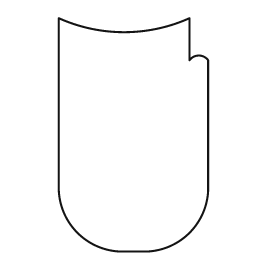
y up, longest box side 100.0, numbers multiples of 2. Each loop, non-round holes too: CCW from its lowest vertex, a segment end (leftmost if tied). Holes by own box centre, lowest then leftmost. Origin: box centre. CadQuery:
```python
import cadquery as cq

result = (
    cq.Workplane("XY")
    .moveTo(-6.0, -50.0)
    .lineTo(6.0, -50.0)
    .threePointArc((24.0, -42.0), (32.0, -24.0))
    .lineTo(32.0, 32.0)
    .threePointArc((28.0, 34.0), (24.0, 32.0))
    .lineTo(24.0, 50.0)
    .threePointArc((-4.0, 44.0), (-32.0, 50.0))
    .lineTo(-32.0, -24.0)
    .threePointArc((-24.0, -42.0), (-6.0, -50.0))
    .close()
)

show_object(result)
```